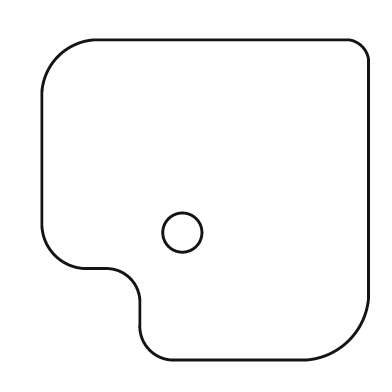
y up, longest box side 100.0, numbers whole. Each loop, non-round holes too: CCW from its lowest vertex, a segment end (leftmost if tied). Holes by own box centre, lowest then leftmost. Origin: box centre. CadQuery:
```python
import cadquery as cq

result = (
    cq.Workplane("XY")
    .moveTo(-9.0, -49.0)
    .lineTo(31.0, -49.0)
    .threePointArc((44.0, -43.0), (50.0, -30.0))
    .lineTo(50.0, 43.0)
    .threePointArc((48.0, 47.0), (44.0, 49.0))
    .lineTo(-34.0, 49.0)
    .threePointArc((-45.0, 44.0), (-50.0, 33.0))
    .lineTo(-50.0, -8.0)
    .threePointArc((-46.0, -17.0), (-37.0, -21.0))
    .lineTo(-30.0, -21.0)
    .threePointArc((-23.0, -24.0), (-20.0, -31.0))
    .lineTo(-20.0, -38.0)
    .threePointArc((-17.0, -46.0), (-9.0, -49.0))
    .close()
    .moveTo(-7.0, -10.0)
    .circle(6.0)
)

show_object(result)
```